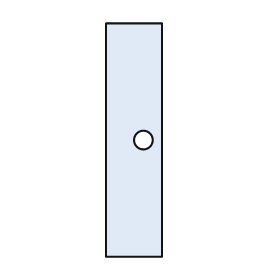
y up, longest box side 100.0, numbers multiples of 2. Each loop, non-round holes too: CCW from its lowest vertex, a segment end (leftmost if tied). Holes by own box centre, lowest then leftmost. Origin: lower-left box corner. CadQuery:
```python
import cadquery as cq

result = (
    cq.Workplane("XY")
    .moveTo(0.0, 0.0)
    .lineTo(24.0, 0.0)
    .lineTo(24.0, 100.0)
    .lineTo(0.0, 100.0)
    .close()
    .moveTo(16.0, 50.0)
    .circle(4.0)
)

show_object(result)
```